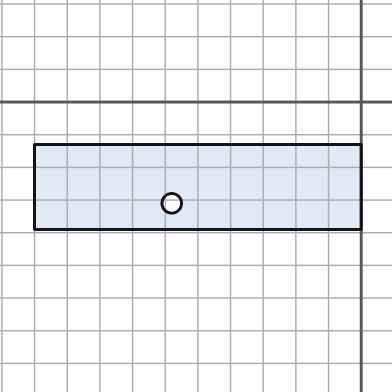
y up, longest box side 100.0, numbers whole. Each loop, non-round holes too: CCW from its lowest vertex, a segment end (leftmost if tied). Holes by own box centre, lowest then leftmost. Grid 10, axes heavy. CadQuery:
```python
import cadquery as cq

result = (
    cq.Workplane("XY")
    .moveTo(-100.0, -39.0)
    .lineTo(0.0, -39.0)
    .lineTo(0.0, -13.0)
    .lineTo(-100.0, -13.0)
    .close()
    .moveTo(-58.0, -31.0)
    .circle(3.0)
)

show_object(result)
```